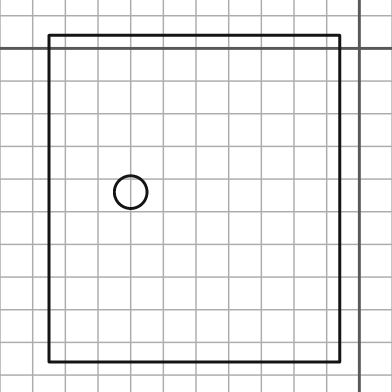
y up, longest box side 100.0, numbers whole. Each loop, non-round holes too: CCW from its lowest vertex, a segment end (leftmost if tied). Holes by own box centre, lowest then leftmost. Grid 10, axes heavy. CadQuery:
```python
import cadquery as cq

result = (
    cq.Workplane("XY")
    .moveTo(-95.0, -96.0)
    .lineTo(-6.0, -96.0)
    .lineTo(-6.0, 4.0)
    .lineTo(-95.0, 4.0)
    .close()
    .moveTo(-70.0, -44.0)
    .circle(5.0)
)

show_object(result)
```